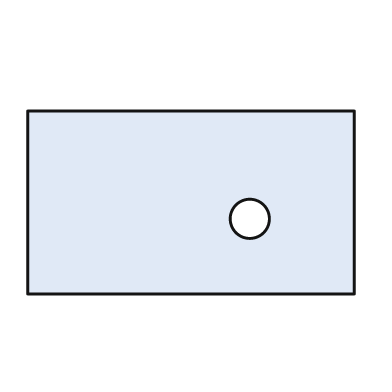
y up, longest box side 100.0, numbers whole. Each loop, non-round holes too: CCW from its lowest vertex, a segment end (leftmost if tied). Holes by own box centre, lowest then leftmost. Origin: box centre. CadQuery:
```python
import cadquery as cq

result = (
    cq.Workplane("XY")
    .moveTo(-50.0, -28.0)
    .lineTo(50.0, -28.0)
    .lineTo(50.0, 28.0)
    .lineTo(-50.0, 28.0)
    .close()
    .moveTo(18.0, -5.0)
    .circle(6.0)
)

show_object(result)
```